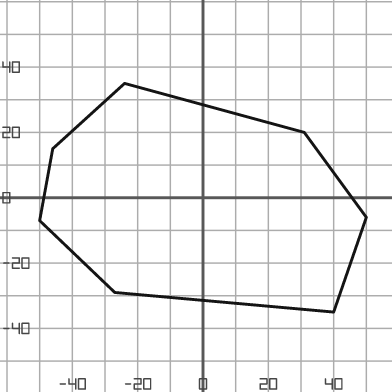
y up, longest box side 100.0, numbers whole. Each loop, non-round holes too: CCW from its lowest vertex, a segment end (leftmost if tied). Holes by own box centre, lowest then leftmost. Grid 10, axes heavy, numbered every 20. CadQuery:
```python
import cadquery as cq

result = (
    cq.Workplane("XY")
    .moveTo(40.0, -35.0)
    .lineTo(50.0, -6.0)
    .lineTo(31.0, 20.0)
    .lineTo(-24.0, 35.0)
    .lineTo(-46.0, 15.0)
    .lineTo(-50.0, -7.0)
    .lineTo(-27.0, -29.0)
    .close()
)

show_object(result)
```